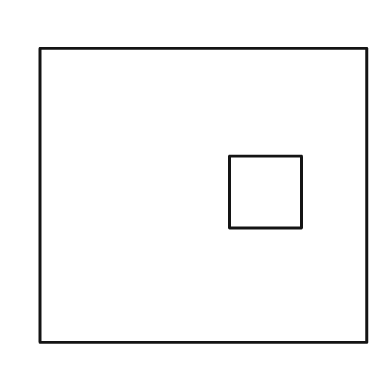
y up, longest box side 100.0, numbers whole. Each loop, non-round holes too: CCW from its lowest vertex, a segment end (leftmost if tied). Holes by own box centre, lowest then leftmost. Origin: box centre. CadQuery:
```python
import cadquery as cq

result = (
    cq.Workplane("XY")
    .moveTo(-50.0, -45.0)
    .lineTo(50.0, -45.0)
    .lineTo(50.0, 45.0)
    .lineTo(-50.0, 45.0)
    .close()
    .moveTo(8.0, -10.0)
    .lineTo(30.0, -10.0)
    .lineTo(30.0, 12.0)
    .lineTo(8.0, 12.0)
    .close()
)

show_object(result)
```